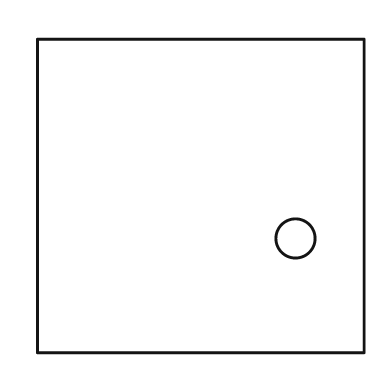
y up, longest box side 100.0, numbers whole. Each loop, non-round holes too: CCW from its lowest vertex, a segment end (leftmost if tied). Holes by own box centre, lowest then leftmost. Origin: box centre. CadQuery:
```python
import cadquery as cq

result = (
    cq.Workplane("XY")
    .moveTo(-50.0, -48.0)
    .lineTo(50.0, -48.0)
    .lineTo(50.0, 48.0)
    .lineTo(-50.0, 48.0)
    .close()
    .moveTo(29.0, -13.0)
    .circle(6.0)
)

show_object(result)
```